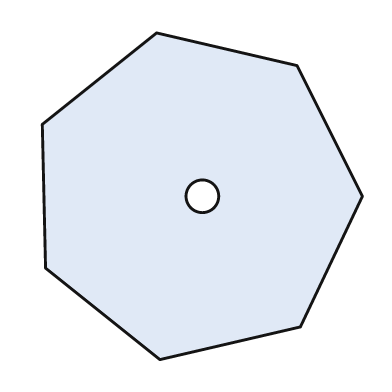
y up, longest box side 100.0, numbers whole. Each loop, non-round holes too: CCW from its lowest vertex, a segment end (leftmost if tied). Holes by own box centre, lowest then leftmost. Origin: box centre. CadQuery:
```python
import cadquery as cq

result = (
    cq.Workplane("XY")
    .moveTo(-13.0, -50.0)
    .lineTo(30.0, -40.0)
    .lineTo(49.0, 0.0)
    .lineTo(29.0, 40.0)
    .lineTo(-14.0, 50.0)
    .lineTo(-49.0, 22.0)
    .lineTo(-48.0, -22.0)
    .close()
    .moveTo(0.0, 0.0)
    .circle(5.0)
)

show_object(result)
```